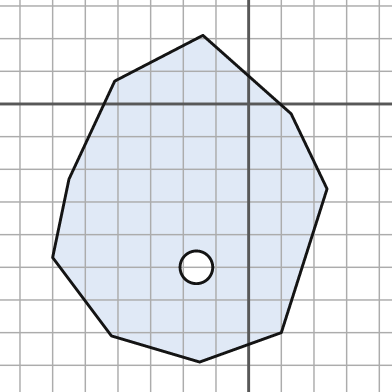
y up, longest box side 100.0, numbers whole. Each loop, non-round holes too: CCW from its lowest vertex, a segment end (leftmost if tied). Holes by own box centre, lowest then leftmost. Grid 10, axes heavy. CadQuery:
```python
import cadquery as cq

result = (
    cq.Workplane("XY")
    .moveTo(-15.0, -79.0)
    .lineTo(10.0, -70.0)
    .lineTo(24.0, -26.0)
    .lineTo(13.0, -3.0)
    .lineTo(-14.0, 21.0)
    .lineTo(-41.0, 7.0)
    .lineTo(-55.0, -23.0)
    .lineTo(-60.0, -47.0)
    .lineTo(-42.0, -71.0)
    .close()
    .moveTo(-16.0, -50.0)
    .circle(5.0)
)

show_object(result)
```